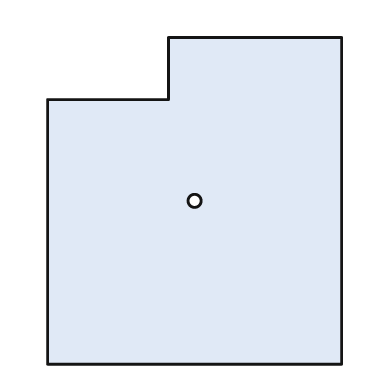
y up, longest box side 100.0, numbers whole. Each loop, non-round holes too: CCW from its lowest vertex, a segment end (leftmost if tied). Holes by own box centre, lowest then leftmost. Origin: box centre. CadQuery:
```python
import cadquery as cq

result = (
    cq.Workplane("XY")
    .moveTo(-45.0, -50.0)
    .lineTo(45.0, -50.0)
    .lineTo(45.0, 50.0)
    .lineTo(-8.0, 50.0)
    .lineTo(-8.0, 31.0)
    .lineTo(-45.0, 31.0)
    .close()
    .moveTo(0.0, 0.0)
    .circle(2.0)
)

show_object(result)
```